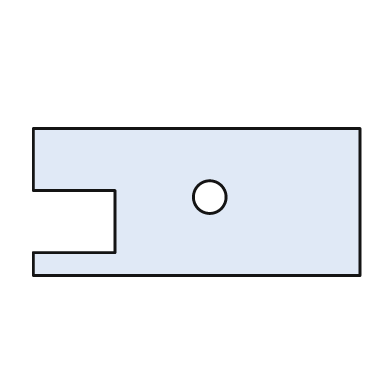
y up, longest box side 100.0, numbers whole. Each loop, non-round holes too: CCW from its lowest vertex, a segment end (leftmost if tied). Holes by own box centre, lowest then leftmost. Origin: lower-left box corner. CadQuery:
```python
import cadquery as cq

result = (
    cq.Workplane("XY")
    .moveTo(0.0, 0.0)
    .lineTo(100.0, 0.0)
    .lineTo(100.0, 45.0)
    .lineTo(0.0, 45.0)
    .lineTo(0.0, 26.0)
    .lineTo(25.0, 26.0)
    .lineTo(25.0, 7.0)
    .lineTo(0.0, 7.0)
    .close()
    .moveTo(54.0, 24.0)
    .circle(5.0)
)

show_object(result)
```